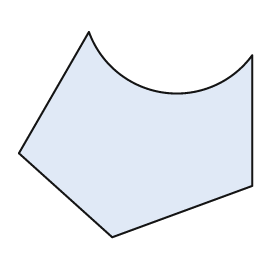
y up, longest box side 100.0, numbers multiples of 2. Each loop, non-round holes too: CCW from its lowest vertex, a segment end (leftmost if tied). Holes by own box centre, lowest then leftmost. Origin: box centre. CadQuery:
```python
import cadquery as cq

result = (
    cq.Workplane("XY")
    .moveTo(-10.0, -44.0)
    .lineTo(50.0, -22.0)
    .lineTo(50.0, 34.0)
    .threePointArc((12.0, 18.0), (-20.0, 44.0))
    .lineTo(-50.0, -8.0)
    .close()
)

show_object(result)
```